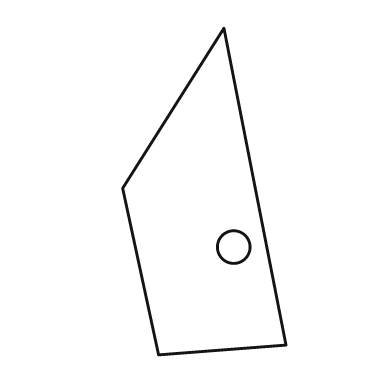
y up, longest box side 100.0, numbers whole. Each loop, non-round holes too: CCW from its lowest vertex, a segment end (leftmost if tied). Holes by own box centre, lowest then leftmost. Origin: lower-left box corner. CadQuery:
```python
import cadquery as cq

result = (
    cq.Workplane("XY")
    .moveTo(11.0, 0.0)
    .lineTo(50.0, 3.0)
    .lineTo(31.0, 100.0)
    .lineTo(0.0, 51.0)
    .close()
    .moveTo(34.0, 33.0)
    .circle(5.0)
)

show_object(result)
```